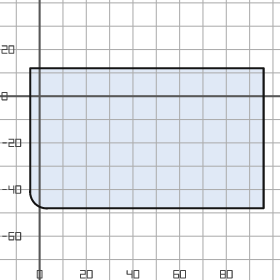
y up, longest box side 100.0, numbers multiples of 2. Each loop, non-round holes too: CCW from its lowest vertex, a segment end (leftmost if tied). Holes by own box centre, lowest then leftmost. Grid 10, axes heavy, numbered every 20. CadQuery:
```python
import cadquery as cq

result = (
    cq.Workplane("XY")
    .moveTo(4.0, -48.0)
    .lineTo(96.0, -48.0)
    .lineTo(96.0, 12.0)
    .lineTo(-4.0, 12.0)
    .lineTo(-4.0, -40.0)
    .threePointArc((-2.0, -46.0), (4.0, -48.0))
    .close()
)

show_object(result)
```